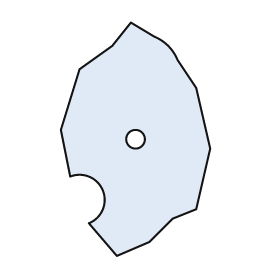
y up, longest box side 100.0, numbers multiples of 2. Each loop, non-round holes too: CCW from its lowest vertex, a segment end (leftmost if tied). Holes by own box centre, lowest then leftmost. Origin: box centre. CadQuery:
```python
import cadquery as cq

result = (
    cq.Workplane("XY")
    .moveTo(-8.0, -50.0)
    .lineTo(6.0, -44.0)
    .lineTo(16.0, -34.0)
    .lineTo(26.0, -30.0)
    .lineTo(32.0, -4.0)
    .lineTo(26.0, 22.0)
    .lineTo(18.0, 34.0)
    .threePointArc((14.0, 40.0), (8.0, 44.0))
    .lineTo(-2.0, 50.0)
    .lineTo(-10.0, 40.0)
    .lineTo(-24.0, 30.0)
    .lineTo(-32.0, 4.0)
    .lineTo(-28.0, -16.0)
    .threePointArc((-14.0, -22.0), (-20.0, -36.0))
    .close()
    .moveTo(0.0, 0.0)
    .circle(4.0)
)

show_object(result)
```